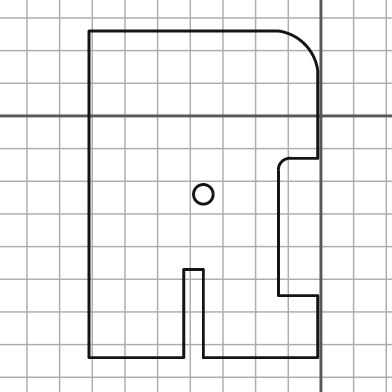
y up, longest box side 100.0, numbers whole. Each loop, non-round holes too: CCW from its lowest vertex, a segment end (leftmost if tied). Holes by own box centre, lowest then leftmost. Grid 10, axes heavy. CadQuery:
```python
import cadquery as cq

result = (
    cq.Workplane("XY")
    .moveTo(-71.0, -74.0)
    .lineTo(-42.0, -74.0)
    .lineTo(-42.0, -47.0)
    .lineTo(-36.0, -47.0)
    .lineTo(-36.0, -74.0)
    .lineTo(-1.0, -74.0)
    .lineTo(-1.0, -55.0)
    .lineTo(-13.0, -55.0)
    .lineTo(-13.0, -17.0)
    .threePointArc((-12.0, -14.0), (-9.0, -13.0))
    .lineTo(-1.0, -13.0)
    .lineTo(-1.0, 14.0)
    .threePointArc((-5.0, 22.0), (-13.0, 26.0))
    .lineTo(-71.0, 26.0)
    .close()
    .moveTo(-36.0, -24.0)
    .circle(3.0)
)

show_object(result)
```